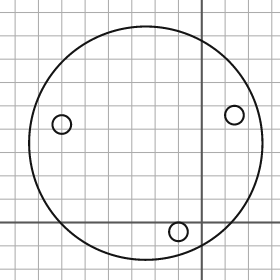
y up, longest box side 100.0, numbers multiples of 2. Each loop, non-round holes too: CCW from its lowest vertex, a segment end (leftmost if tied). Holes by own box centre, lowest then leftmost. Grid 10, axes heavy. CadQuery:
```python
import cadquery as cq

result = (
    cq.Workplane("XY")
    .moveTo(-24.0, 34.0)
    .circle(50.0)
    .moveTo(-10.0, -4.0)
    .circle(4.0)
    .moveTo(-60.0, 42.0)
    .circle(4.0)
    .moveTo(14.0, 46.0)
    .circle(4.0)
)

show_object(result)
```